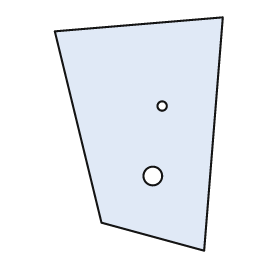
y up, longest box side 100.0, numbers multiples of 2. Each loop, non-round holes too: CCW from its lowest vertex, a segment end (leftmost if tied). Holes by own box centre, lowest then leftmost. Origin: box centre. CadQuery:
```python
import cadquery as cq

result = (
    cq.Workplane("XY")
    .moveTo(28.0, -50.0)
    .lineTo(36.0, 50.0)
    .lineTo(-36.0, 44.0)
    .lineTo(-16.0, -38.0)
    .close()
    .moveTo(6.0, -18.0)
    .circle(4.0)
    .moveTo(10.0, 12.0)
    .circle(2.0)
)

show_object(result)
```